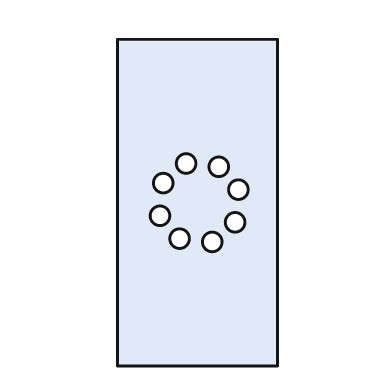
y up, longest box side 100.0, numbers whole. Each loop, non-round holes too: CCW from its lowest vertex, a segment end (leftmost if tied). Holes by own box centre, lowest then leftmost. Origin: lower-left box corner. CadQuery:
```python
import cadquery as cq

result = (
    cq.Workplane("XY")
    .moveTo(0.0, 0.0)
    .lineTo(49.0, 0.0)
    .lineTo(49.0, 100.0)
    .lineTo(0.0, 100.0)
    .close()
    .moveTo(29.0, 38.0)
    .circle(3.0)
    .moveTo(19.0, 39.0)
    .circle(3.0)
    .moveTo(36.0, 44.0)
    .circle(3.0)
    .moveTo(13.0, 46.0)
    .circle(3.0)
    .moveTo(37.0, 54.0)
    .circle(3.0)
    .moveTo(14.0, 56.0)
    .circle(3.0)
    .moveTo(31.0, 61.0)
    .circle(3.0)
    .moveTo(21.0, 62.0)
    .circle(3.0)
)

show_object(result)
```